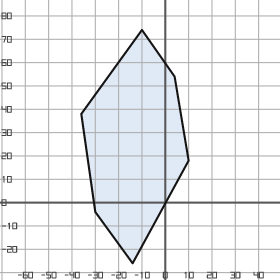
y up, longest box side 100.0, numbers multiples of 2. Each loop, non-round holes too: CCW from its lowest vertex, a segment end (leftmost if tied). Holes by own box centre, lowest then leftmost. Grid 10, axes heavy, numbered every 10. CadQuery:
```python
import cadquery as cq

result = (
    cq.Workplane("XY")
    .moveTo(-14.0, -26.0)
    .lineTo(10.0, 18.0)
    .lineTo(4.0, 54.0)
    .lineTo(-10.0, 74.0)
    .lineTo(-36.0, 38.0)
    .lineTo(-30.0, -4.0)
    .close()
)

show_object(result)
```